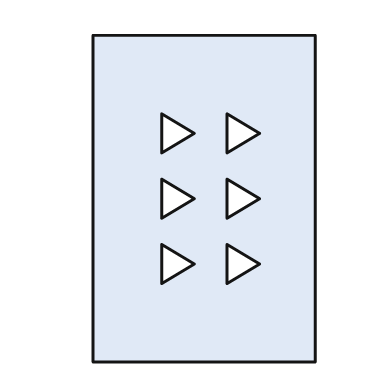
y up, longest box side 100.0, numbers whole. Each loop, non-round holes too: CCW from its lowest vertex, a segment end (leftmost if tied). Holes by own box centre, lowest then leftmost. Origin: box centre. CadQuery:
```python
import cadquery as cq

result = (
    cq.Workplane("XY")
    .moveTo(-34.0, -50.0)
    .lineTo(34.0, -50.0)
    .lineTo(34.0, 50.0)
    .lineTo(-34.0, 50.0)
    .close()
    .moveTo(-13.0, -26.0)
    .lineTo(-3.0, -20.0)
    .lineTo(-13.0, -14.0)
    .close()
    .moveTo(7.0, -26.0)
    .lineTo(17.0, -20.0)
    .lineTo(7.0, -14.0)
    .close()
    .moveTo(-13.0, -6.0)
    .lineTo(-3.0, 0.0)
    .lineTo(-13.0, 6.0)
    .close()
    .moveTo(7.0, -6.0)
    .lineTo(17.0, 0.0)
    .lineTo(7.0, 6.0)
    .close()
    .moveTo(-13.0, 14.0)
    .lineTo(-3.0, 20.0)
    .lineTo(-13.0, 26.0)
    .close()
    .moveTo(7.0, 14.0)
    .lineTo(17.0, 20.0)
    .lineTo(7.0, 26.0)
    .close()
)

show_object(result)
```